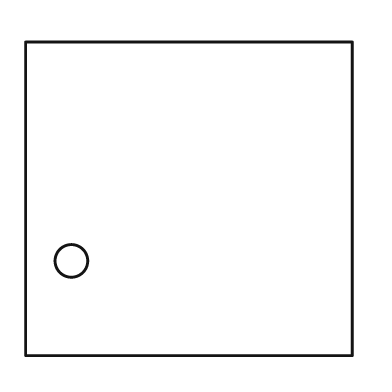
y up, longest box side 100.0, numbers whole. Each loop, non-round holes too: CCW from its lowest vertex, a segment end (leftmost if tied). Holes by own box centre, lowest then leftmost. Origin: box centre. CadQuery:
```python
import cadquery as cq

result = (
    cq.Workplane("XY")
    .moveTo(-50.0, -48.0)
    .lineTo(50.0, -48.0)
    .lineTo(50.0, 48.0)
    .lineTo(-50.0, 48.0)
    .close()
    .moveTo(-36.0, -19.0)
    .circle(5.0)
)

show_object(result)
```